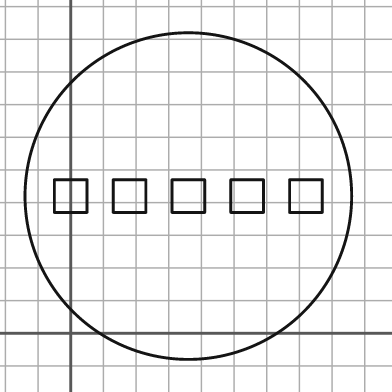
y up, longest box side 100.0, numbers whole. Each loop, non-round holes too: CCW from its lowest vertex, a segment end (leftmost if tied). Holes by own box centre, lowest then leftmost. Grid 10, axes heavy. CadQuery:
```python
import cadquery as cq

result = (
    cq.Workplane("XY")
    .moveTo(36.0, 42.0)
    .circle(50.0)
    .moveTo(-5.0, 37.0)
    .lineTo(5.0, 37.0)
    .lineTo(5.0, 47.0)
    .lineTo(-5.0, 47.0)
    .close()
    .moveTo(13.0, 37.0)
    .lineTo(23.0, 37.0)
    .lineTo(23.0, 47.0)
    .lineTo(13.0, 47.0)
    .close()
    .moveTo(31.0, 37.0)
    .lineTo(41.0, 37.0)
    .lineTo(41.0, 47.0)
    .lineTo(31.0, 47.0)
    .close()
    .moveTo(49.0, 37.0)
    .lineTo(59.0, 37.0)
    .lineTo(59.0, 47.0)
    .lineTo(49.0, 47.0)
    .close()
    .moveTo(67.0, 37.0)
    .lineTo(77.0, 37.0)
    .lineTo(77.0, 47.0)
    .lineTo(67.0, 47.0)
    .close()
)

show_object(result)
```